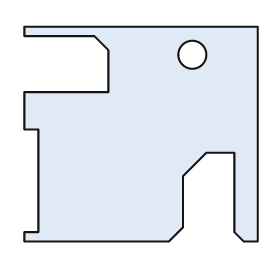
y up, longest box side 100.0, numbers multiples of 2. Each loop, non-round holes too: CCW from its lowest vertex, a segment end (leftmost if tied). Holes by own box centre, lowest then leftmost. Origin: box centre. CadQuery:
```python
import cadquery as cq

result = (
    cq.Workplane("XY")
    .moveTo(-50.0, -46.0)
    .lineTo(12.0, -46.0)
    .lineTo(18.0, -40.0)
    .lineTo(18.0, -18.0)
    .lineTo(28.0, -8.0)
    .lineTo(40.0, -8.0)
    .lineTo(40.0, -42.0)
    .lineTo(44.0, -46.0)
    .lineTo(50.0, -46.0)
    .lineTo(50.0, 46.0)
    .lineTo(-50.0, 46.0)
    .lineTo(-50.0, 42.0)
    .lineTo(-20.0, 42.0)
    .lineTo(-14.0, 36.0)
    .lineTo(-14.0, 18.0)
    .lineTo(-50.0, 18.0)
    .lineTo(-50.0, 2.0)
    .lineTo(-44.0, 2.0)
    .lineTo(-44.0, -42.0)
    .lineTo(-50.0, -42.0)
    .close()
    .moveTo(22.0, 34.0)
    .circle(6.0)
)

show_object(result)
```